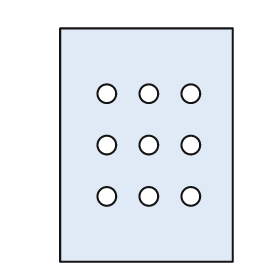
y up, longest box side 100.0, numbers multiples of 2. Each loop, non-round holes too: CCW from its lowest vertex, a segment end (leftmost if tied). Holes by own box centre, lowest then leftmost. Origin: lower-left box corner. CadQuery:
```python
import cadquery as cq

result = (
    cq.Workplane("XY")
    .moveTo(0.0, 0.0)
    .lineTo(74.0, 0.0)
    .lineTo(74.0, 100.0)
    .lineTo(0.0, 100.0)
    .close()
    .moveTo(20.0, 28.0)
    .circle(4.0)
    .moveTo(38.0, 28.0)
    .circle(4.0)
    .moveTo(56.0, 28.0)
    .circle(4.0)
    .moveTo(20.0, 50.0)
    .circle(4.0)
    .moveTo(38.0, 50.0)
    .circle(4.0)
    .moveTo(56.0, 50.0)
    .circle(4.0)
    .moveTo(20.0, 72.0)
    .circle(4.0)
    .moveTo(38.0, 72.0)
    .circle(4.0)
    .moveTo(56.0, 72.0)
    .circle(4.0)
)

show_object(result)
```